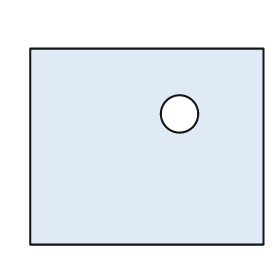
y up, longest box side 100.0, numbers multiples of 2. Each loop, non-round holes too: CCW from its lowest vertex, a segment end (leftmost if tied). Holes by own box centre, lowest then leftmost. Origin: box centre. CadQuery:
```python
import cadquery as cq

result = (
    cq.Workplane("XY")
    .moveTo(-50.0, -42.0)
    .lineTo(50.0, -42.0)
    .lineTo(50.0, 42.0)
    .lineTo(-50.0, 42.0)
    .close()
    .moveTo(14.0, 14.0)
    .circle(8.0)
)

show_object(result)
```